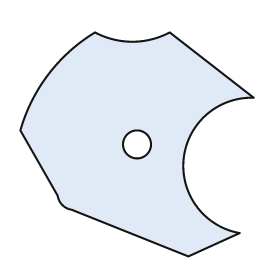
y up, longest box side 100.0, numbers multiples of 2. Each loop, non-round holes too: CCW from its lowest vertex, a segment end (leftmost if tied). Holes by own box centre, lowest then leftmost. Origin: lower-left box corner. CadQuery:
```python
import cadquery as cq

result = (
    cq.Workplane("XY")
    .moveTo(72.0, 0.0)
    .lineTo(94.0, 10.0)
    .threePointArc((70.0, 42.0), (100.0, 68.0))
    .lineTo(64.0, 96.0)
    .threePointArc((48.0, 92.0), (32.0, 96.0))
    .threePointArc((12.0, 78.0), (0.0, 54.0))
    .lineTo(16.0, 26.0)
    .threePointArc((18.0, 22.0), (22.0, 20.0))
    .close()
    .moveTo(50.0, 48.0)
    .circle(6.0)
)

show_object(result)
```